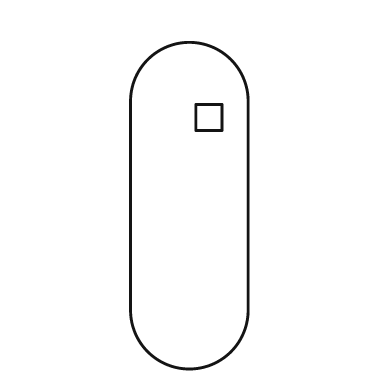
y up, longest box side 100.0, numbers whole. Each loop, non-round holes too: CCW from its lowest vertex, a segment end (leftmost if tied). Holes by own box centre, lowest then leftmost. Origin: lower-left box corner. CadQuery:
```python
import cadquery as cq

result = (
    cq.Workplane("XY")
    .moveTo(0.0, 18.0)
    .threePointArc((18.0, 0.0), (36.0, 18.0))
    .lineTo(36.0, 82.0)
    .threePointArc((18.0, 100.0), (0.0, 82.0))
    .close()
    .moveTo(20.0, 73.0)
    .lineTo(28.0, 73.0)
    .lineTo(28.0, 81.0)
    .lineTo(20.0, 81.0)
    .close()
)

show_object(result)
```